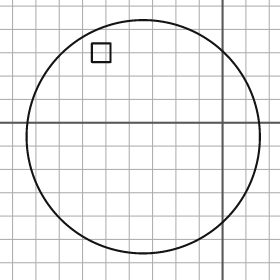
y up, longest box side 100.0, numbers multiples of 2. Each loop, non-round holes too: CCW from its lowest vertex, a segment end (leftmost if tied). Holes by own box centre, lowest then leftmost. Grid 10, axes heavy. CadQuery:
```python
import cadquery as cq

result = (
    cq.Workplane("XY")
    .moveTo(-34.0, -6.0)
    .circle(50.0)
    .moveTo(-56.0, 26.0)
    .lineTo(-48.0, 26.0)
    .lineTo(-48.0, 34.0)
    .lineTo(-56.0, 34.0)
    .close()
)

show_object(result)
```